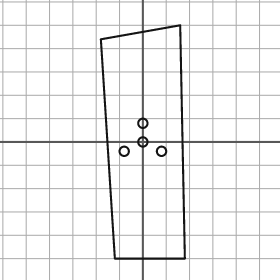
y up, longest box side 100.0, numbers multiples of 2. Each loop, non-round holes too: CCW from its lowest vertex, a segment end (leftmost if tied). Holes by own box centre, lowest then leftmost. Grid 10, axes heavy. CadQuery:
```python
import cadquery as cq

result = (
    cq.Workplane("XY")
    .moveTo(-12.0, -50.0)
    .lineTo(18.0, -50.0)
    .lineTo(16.0, 50.0)
    .lineTo(-18.0, 44.0)
    .close()
    .moveTo(-8.0, -4.0)
    .circle(2.0)
    .moveTo(8.0, -4.0)
    .circle(2.0)
    .moveTo(0.0, 0.0)
    .circle(2.0)
    .moveTo(0.0, 8.0)
    .circle(2.0)
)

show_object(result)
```